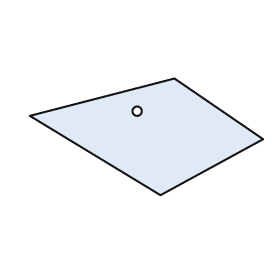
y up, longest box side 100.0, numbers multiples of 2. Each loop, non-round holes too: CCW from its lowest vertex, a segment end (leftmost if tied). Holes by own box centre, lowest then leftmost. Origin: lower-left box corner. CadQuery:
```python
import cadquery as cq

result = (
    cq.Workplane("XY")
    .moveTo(56.0, 0.0)
    .lineTo(100.0, 24.0)
    .lineTo(62.0, 50.0)
    .lineTo(0.0, 34.0)
    .close()
    .moveTo(46.0, 36.0)
    .circle(2.0)
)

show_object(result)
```